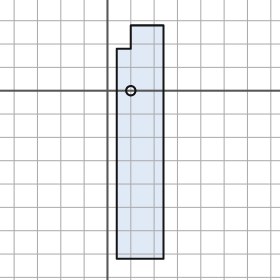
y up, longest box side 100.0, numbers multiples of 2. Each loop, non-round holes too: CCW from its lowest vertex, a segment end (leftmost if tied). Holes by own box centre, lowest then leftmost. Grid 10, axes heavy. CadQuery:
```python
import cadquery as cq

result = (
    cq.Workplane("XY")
    .moveTo(4.0, -72.0)
    .lineTo(24.0, -72.0)
    .lineTo(24.0, 28.0)
    .lineTo(10.0, 28.0)
    .lineTo(10.0, 18.0)
    .lineTo(4.0, 18.0)
    .close()
    .moveTo(10.0, 0.0)
    .circle(2.0)
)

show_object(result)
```